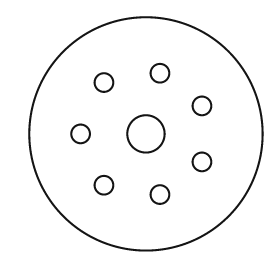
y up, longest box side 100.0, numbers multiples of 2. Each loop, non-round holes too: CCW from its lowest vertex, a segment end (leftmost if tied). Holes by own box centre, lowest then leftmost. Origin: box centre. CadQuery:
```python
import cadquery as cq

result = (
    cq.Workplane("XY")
    .moveTo(0.0, 0.0)
    .circle(50.0)
    .moveTo(6.0, -26.0)
    .circle(4.0)
    .moveTo(-18.0, -22.0)
    .circle(4.0)
    .moveTo(24.0, -12.0)
    .circle(4.0)
    .moveTo(-28.0, 0.0)
    .circle(4.0)
    .moveTo(0.0, 0.0)
    .circle(8.0)
    .moveTo(24.0, 12.0)
    .circle(4.0)
    .moveTo(-18.0, 22.0)
    .circle(4.0)
    .moveTo(6.0, 26.0)
    .circle(4.0)
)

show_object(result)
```